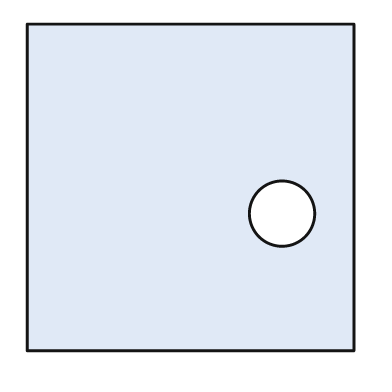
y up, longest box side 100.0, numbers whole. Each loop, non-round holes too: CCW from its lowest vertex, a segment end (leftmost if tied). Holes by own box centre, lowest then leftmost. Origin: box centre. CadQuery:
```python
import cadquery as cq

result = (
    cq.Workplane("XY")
    .moveTo(-50.0, -50.0)
    .lineTo(50.0, -50.0)
    .lineTo(50.0, 50.0)
    .lineTo(-50.0, 50.0)
    .close()
    .moveTo(28.0, -8.0)
    .circle(10.0)
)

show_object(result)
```